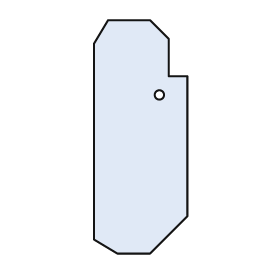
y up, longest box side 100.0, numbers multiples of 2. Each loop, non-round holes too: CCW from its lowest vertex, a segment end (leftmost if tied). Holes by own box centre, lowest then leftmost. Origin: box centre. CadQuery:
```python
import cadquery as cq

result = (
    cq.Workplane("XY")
    .moveTo(-10.0, -50.0)
    .lineTo(4.0, -50.0)
    .lineTo(20.0, -34.0)
    .lineTo(20.0, 26.0)
    .lineTo(12.0, 26.0)
    .lineTo(12.0, 42.0)
    .lineTo(4.0, 50.0)
    .lineTo(-14.0, 50.0)
    .lineTo(-20.0, 40.0)
    .lineTo(-20.0, -44.0)
    .close()
    .moveTo(8.0, 18.0)
    .circle(2.0)
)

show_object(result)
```